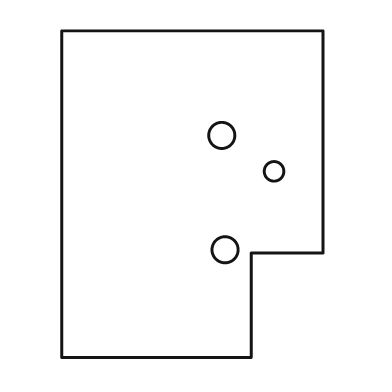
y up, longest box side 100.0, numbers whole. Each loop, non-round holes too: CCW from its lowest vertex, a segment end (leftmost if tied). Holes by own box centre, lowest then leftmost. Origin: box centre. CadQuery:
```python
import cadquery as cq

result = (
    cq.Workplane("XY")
    .moveTo(-40.0, -50.0)
    .lineTo(18.0, -50.0)
    .lineTo(18.0, -18.0)
    .lineTo(40.0, -18.0)
    .lineTo(40.0, 50.0)
    .lineTo(-40.0, 50.0)
    .close()
    .moveTo(10.0, -17.0)
    .circle(4.0)
    .moveTo(25.0, 7.0)
    .circle(3.0)
    .moveTo(9.0, 18.0)
    .circle(4.0)
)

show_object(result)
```